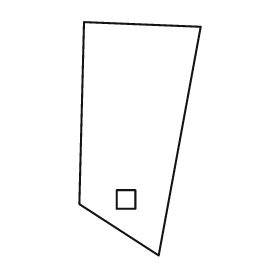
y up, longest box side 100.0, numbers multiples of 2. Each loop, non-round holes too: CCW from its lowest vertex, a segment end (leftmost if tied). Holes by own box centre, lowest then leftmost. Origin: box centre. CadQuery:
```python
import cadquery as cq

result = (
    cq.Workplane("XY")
    .moveTo(8.0, -50.0)
    .lineTo(26.0, 48.0)
    .lineTo(-24.0, 50.0)
    .lineTo(-26.0, -28.0)
    .close()
    .moveTo(-10.0, -30.0)
    .lineTo(-2.0, -30.0)
    .lineTo(-2.0, -22.0)
    .lineTo(-10.0, -22.0)
    .close()
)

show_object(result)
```